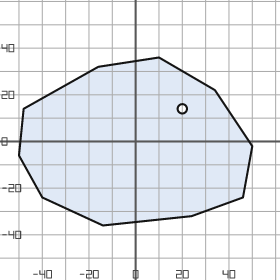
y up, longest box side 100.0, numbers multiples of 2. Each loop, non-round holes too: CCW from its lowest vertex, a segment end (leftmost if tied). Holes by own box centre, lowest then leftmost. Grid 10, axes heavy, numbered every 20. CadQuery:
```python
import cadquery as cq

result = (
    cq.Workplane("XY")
    .moveTo(-14.0, -36.0)
    .lineTo(24.0, -32.0)
    .lineTo(46.0, -24.0)
    .lineTo(50.0, -2.0)
    .lineTo(34.0, 22.0)
    .lineTo(10.0, 36.0)
    .lineTo(-16.0, 32.0)
    .lineTo(-48.0, 14.0)
    .lineTo(-50.0, -6.0)
    .lineTo(-40.0, -24.0)
    .close()
    .moveTo(20.0, 14.0)
    .circle(2.0)
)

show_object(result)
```